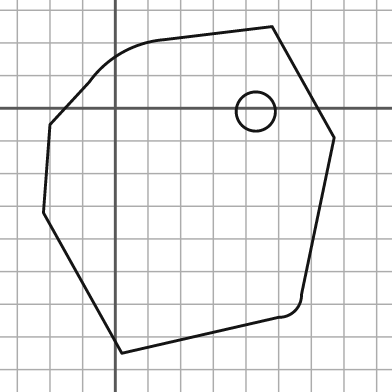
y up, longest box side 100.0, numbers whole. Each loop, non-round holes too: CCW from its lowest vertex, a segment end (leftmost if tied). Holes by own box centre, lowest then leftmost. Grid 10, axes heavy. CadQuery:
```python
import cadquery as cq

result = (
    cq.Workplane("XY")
    .moveTo(2.0, -75.0)
    .lineTo(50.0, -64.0)
    .threePointArc((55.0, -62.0), (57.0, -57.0))
    .lineTo(67.0, -9.0)
    .lineTo(48.0, 25.0)
    .lineTo(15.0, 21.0)
    .threePointArc((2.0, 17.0), (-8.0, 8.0))
    .lineTo(-20.0, -5.0)
    .lineTo(-22.0, -32.0)
    .close()
    .moveTo(43.0, -1.0)
    .circle(6.0)
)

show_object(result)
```